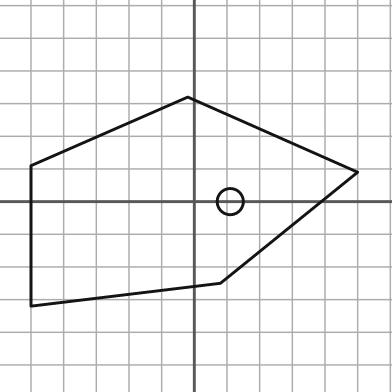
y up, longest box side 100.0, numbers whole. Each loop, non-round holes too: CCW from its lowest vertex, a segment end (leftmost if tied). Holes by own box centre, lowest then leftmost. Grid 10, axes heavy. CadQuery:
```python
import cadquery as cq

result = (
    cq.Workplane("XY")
    .moveTo(-50.0, -32.0)
    .lineTo(8.0, -25.0)
    .lineTo(50.0, 9.0)
    .lineTo(-2.0, 32.0)
    .lineTo(-50.0, 11.0)
    .close()
    .moveTo(11.0, 0.0)
    .circle(4.0)
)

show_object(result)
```